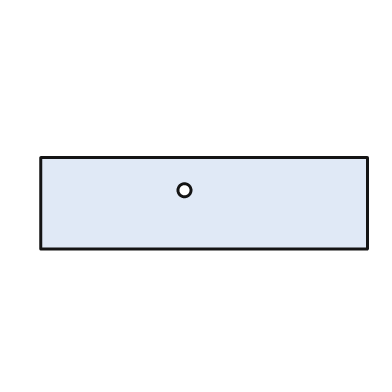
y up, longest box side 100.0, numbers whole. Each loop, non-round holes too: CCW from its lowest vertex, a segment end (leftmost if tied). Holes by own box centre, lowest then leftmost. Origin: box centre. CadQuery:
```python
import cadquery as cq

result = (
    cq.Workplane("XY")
    .moveTo(-50.0, -14.0)
    .lineTo(50.0, -14.0)
    .lineTo(50.0, 14.0)
    .lineTo(-50.0, 14.0)
    .close()
    .moveTo(-6.0, 4.0)
    .circle(2.0)
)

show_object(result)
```